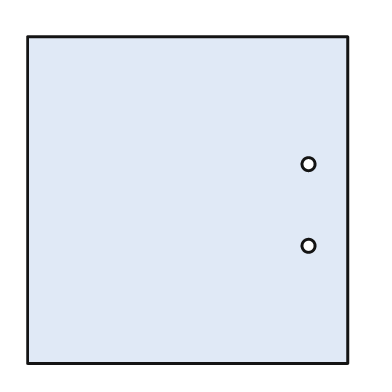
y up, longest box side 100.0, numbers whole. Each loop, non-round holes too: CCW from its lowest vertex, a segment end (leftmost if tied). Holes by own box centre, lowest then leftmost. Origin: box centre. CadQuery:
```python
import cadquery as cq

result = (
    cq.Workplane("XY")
    .moveTo(-49.0, -50.0)
    .lineTo(49.0, -50.0)
    .lineTo(49.0, 50.0)
    .lineTo(-49.0, 50.0)
    .close()
    .moveTo(37.0, -14.0)
    .circle(2.0)
    .moveTo(37.0, 11.0)
    .circle(2.0)
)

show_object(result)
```